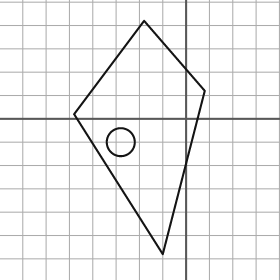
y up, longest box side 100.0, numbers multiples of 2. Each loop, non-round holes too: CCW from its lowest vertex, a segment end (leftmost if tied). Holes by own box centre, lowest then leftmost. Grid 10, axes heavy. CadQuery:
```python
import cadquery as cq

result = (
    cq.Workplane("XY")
    .moveTo(-10.0, -58.0)
    .lineTo(8.0, 12.0)
    .lineTo(-18.0, 42.0)
    .lineTo(-48.0, 2.0)
    .close()
    .moveTo(-28.0, -10.0)
    .circle(6.0)
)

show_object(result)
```